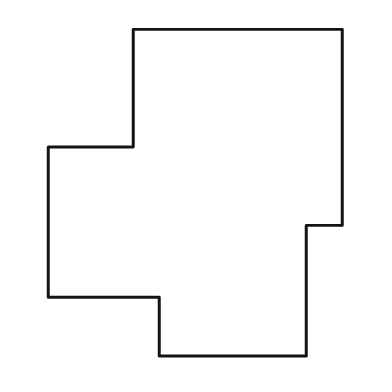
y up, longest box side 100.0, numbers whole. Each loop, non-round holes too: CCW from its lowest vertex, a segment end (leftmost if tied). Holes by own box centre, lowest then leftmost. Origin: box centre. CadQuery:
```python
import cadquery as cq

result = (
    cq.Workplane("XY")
    .moveTo(-11.0, -50.0)
    .lineTo(34.0, -50.0)
    .lineTo(34.0, -10.0)
    .lineTo(45.0, -10.0)
    .lineTo(45.0, 50.0)
    .lineTo(-19.0, 50.0)
    .lineTo(-19.0, 14.0)
    .lineTo(-45.0, 14.0)
    .lineTo(-45.0, -32.0)
    .lineTo(-11.0, -32.0)
    .close()
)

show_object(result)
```